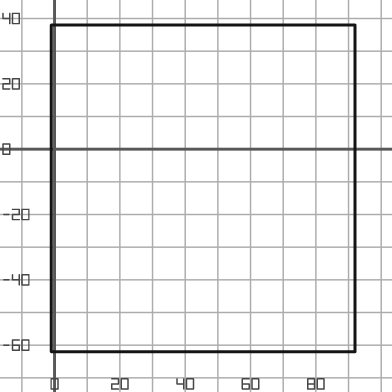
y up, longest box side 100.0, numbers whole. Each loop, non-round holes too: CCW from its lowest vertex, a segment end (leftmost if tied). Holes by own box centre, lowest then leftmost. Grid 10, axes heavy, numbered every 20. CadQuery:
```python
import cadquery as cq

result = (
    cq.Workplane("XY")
    .moveTo(-1.0, -62.0)
    .lineTo(92.0, -62.0)
    .lineTo(92.0, 38.0)
    .lineTo(-1.0, 38.0)
    .close()
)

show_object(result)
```